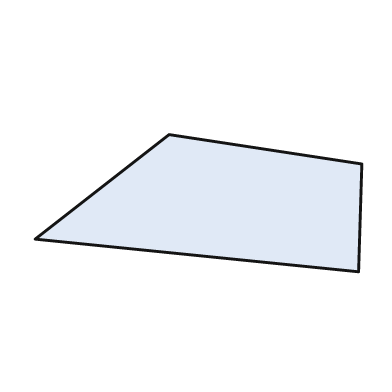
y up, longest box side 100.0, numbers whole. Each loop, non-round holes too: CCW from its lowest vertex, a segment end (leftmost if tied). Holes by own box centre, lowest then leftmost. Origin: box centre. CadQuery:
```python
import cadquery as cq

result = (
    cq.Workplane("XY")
    .moveTo(49.0, -21.0)
    .lineTo(50.0, 12.0)
    .lineTo(-9.0, 21.0)
    .lineTo(-50.0, -11.0)
    .close()
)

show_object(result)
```